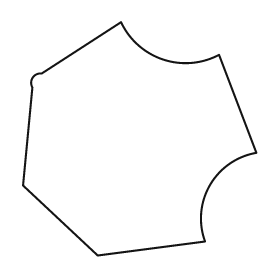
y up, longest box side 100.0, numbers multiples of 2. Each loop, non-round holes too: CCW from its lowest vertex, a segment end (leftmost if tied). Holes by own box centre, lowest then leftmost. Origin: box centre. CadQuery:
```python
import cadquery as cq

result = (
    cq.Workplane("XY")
    .moveTo(-18.0, -50.0)
    .lineTo(28.0, -44.0)
    .threePointArc((30.0, -20.0), (50.0, -6.0))
    .lineTo(34.0, 36.0)
    .threePointArc((10.0, 34.0), (-8.0, 50.0))
    .lineTo(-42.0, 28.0)
    .threePointArc((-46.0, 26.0), (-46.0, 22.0))
    .lineTo(-50.0, -20.0)
    .close()
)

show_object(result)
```